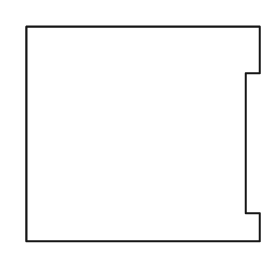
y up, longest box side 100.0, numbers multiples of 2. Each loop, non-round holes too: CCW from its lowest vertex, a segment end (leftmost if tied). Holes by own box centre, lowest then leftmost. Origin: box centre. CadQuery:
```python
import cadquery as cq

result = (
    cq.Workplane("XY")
    .moveTo(-50.0, -46.0)
    .lineTo(50.0, -46.0)
    .lineTo(50.0, -34.0)
    .lineTo(44.0, -34.0)
    .lineTo(44.0, 26.0)
    .lineTo(50.0, 26.0)
    .lineTo(50.0, 46.0)
    .lineTo(-50.0, 46.0)
    .close()
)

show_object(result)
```